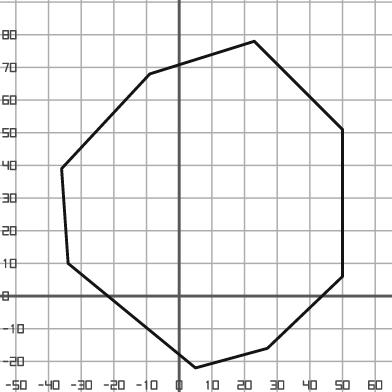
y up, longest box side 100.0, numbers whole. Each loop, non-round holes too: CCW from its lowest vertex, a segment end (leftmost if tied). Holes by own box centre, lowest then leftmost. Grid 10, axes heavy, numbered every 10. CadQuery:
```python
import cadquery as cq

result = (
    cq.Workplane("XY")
    .moveTo(5.0, -22.0)
    .lineTo(27.0, -16.0)
    .lineTo(50.0, 6.0)
    .lineTo(50.0, 51.0)
    .lineTo(23.0, 78.0)
    .lineTo(-9.0, 68.0)
    .lineTo(-36.0, 39.0)
    .lineTo(-34.0, 10.0)
    .close()
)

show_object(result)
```